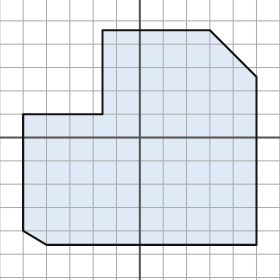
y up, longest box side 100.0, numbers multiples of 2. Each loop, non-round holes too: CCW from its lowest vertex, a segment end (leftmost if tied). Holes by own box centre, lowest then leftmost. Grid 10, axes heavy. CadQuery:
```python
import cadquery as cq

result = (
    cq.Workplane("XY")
    .moveTo(-40.0, -46.0)
    .lineTo(50.0, -46.0)
    .lineTo(50.0, 26.0)
    .lineTo(30.0, 46.0)
    .lineTo(-16.0, 46.0)
    .lineTo(-16.0, 10.0)
    .lineTo(-50.0, 10.0)
    .lineTo(-50.0, -40.0)
    .close()
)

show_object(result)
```